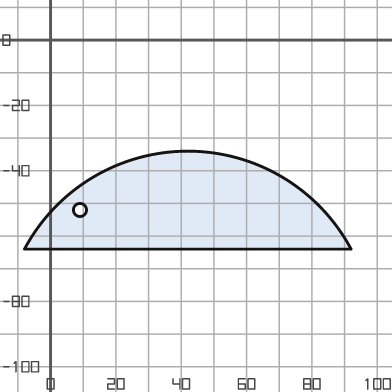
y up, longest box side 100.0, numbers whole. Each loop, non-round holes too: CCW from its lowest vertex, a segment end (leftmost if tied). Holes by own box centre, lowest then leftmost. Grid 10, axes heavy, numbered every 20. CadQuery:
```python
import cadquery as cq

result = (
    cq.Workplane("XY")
    .moveTo(-8.0, -64.0)
    .lineTo(92.0, -64.0)
    .threePointArc((42.0, -34.0), (-8.0, -64.0))
    .close()
    .moveTo(9.0, -52.0)
    .circle(2.0)
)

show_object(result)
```